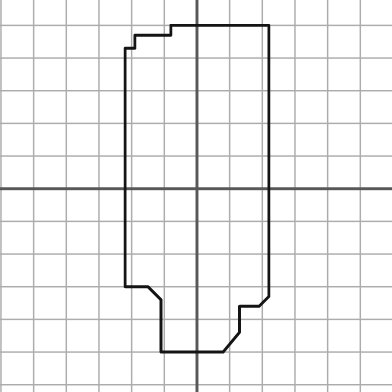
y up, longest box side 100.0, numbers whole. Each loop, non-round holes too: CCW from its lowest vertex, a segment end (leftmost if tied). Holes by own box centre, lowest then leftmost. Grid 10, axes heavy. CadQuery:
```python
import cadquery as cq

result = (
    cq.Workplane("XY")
    .moveTo(-11.0, -50.0)
    .lineTo(8.0, -50.0)
    .lineTo(13.0, -44.0)
    .lineTo(13.0, -36.0)
    .lineTo(19.0, -36.0)
    .lineTo(22.0, -33.0)
    .lineTo(22.0, 50.0)
    .lineTo(-8.0, 50.0)
    .lineTo(-8.0, 47.0)
    .lineTo(-19.0, 47.0)
    .lineTo(-19.0, 43.0)
    .lineTo(-22.0, 43.0)
    .lineTo(-22.0, -30.0)
    .lineTo(-15.0, -30.0)
    .lineTo(-11.0, -34.0)
    .close()
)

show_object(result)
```